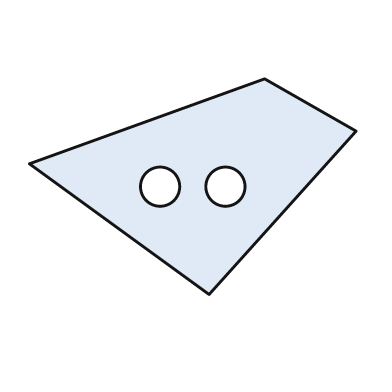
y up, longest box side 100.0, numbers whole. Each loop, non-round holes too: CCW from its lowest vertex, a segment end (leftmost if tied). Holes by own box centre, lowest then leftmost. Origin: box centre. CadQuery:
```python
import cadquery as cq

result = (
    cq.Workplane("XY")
    .moveTo(5.0, -33.0)
    .lineTo(50.0, 17.0)
    .lineTo(22.0, 33.0)
    .lineTo(-50.0, 7.0)
    .close()
    .moveTo(-10.0, 0.0)
    .circle(6.0)
    .moveTo(10.0, 0.0)
    .circle(6.0)
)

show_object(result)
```